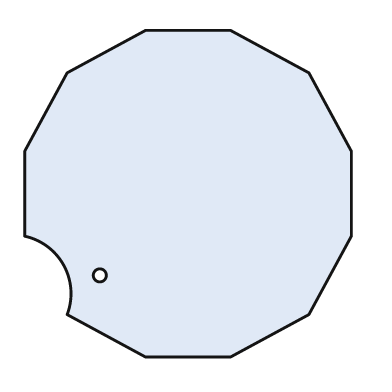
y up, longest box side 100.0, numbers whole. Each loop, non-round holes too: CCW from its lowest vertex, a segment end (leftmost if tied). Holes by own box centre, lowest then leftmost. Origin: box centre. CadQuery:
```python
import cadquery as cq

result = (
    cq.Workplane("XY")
    .moveTo(-13.0, -50.0)
    .lineTo(13.0, -50.0)
    .lineTo(37.0, -37.0)
    .lineTo(50.0, -13.0)
    .lineTo(50.0, 13.0)
    .lineTo(37.0, 37.0)
    .lineTo(13.0, 50.0)
    .lineTo(-13.0, 50.0)
    .lineTo(-37.0, 37.0)
    .lineTo(-50.0, 13.0)
    .lineTo(-50.0, -13.0)
    .threePointArc((-38.0, -22.0), (-37.0, -37.0))
    .close()
    .moveTo(-27.0, -25.0)
    .circle(2.0)
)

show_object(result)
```